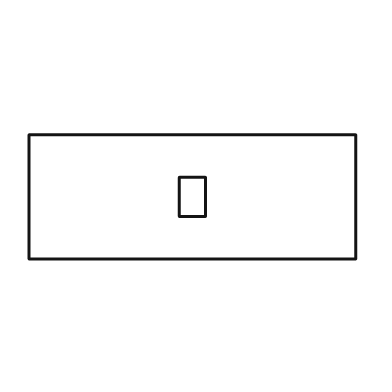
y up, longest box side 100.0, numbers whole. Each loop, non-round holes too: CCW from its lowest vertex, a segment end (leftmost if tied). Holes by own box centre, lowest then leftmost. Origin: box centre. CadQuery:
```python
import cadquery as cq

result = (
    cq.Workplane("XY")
    .moveTo(-50.0, -19.0)
    .lineTo(50.0, -19.0)
    .lineTo(50.0, 19.0)
    .lineTo(-50.0, 19.0)
    .close()
    .moveTo(-4.0, -6.0)
    .lineTo(4.0, -6.0)
    .lineTo(4.0, 6.0)
    .lineTo(-4.0, 6.0)
    .close()
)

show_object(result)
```